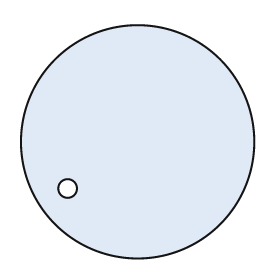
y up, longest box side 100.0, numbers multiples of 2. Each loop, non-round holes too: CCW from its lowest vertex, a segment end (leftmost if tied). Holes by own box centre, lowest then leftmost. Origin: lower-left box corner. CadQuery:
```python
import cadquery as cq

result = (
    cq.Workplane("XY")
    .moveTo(50.0, 50.0)
    .circle(50.0)
    .moveTo(20.0, 30.0)
    .circle(4.0)
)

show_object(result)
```